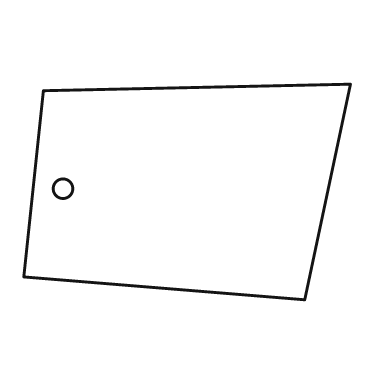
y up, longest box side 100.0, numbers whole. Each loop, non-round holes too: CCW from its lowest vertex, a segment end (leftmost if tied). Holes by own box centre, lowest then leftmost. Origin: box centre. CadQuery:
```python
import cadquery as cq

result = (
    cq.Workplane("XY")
    .moveTo(36.0, -33.0)
    .lineTo(50.0, 33.0)
    .lineTo(-44.0, 31.0)
    .lineTo(-50.0, -26.0)
    .close()
    .moveTo(-38.0, 1.0)
    .circle(3.0)
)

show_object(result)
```